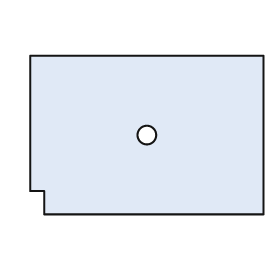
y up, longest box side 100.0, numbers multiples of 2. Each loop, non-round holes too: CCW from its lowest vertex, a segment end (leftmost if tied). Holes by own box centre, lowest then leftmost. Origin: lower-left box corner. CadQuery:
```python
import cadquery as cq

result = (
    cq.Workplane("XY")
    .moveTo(6.0, 0.0)
    .lineTo(100.0, 0.0)
    .lineTo(100.0, 68.0)
    .lineTo(0.0, 68.0)
    .lineTo(0.0, 10.0)
    .lineTo(6.0, 10.0)
    .close()
    .moveTo(50.0, 34.0)
    .circle(4.0)
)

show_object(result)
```